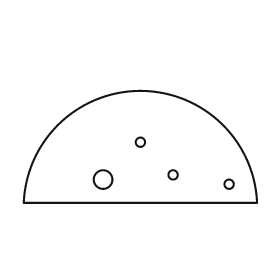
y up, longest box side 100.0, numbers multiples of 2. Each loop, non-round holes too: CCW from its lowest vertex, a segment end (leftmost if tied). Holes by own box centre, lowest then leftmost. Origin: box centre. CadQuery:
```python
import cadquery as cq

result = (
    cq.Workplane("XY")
    .moveTo(-50.0, -24.0)
    .lineTo(50.0, -24.0)
    .threePointArc((0.0, 24.0), (-50.0, -24.0))
    .close()
    .moveTo(38.0, -16.0)
    .circle(2.0)
    .moveTo(-16.0, -14.0)
    .circle(4.0)
    .moveTo(14.0, -12.0)
    .circle(2.0)
    .moveTo(0.0, 2.0)
    .circle(2.0)
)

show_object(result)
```